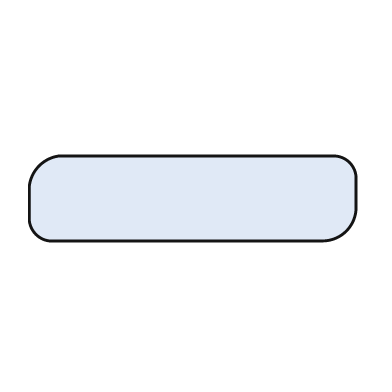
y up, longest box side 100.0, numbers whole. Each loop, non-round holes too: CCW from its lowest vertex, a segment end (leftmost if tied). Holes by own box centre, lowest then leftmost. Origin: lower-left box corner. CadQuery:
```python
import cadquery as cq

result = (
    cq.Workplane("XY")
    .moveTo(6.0, 0.0)
    .lineTo(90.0, 0.0)
    .threePointArc((97.0, 3.0), (100.0, 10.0))
    .lineTo(100.0, 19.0)
    .threePointArc((98.0, 24.0), (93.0, 26.0))
    .lineTo(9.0, 26.0)
    .threePointArc((3.0, 23.0), (0.0, 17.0))
    .lineTo(0.0, 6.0)
    .threePointArc((2.0, 2.0), (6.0, 0.0))
    .close()
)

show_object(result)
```